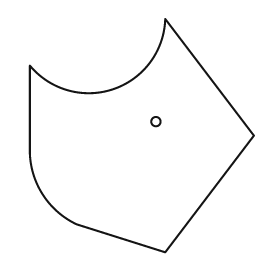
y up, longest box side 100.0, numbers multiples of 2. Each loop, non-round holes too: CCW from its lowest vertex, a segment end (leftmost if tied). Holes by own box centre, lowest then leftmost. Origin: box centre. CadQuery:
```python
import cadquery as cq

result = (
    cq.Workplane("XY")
    .moveTo(10.0, -50.0)
    .lineTo(48.0, 0.0)
    .lineTo(10.0, 50.0)
    .threePointArc((-12.0, 20.0), (-48.0, 30.0))
    .lineTo(-48.0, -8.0)
    .threePointArc((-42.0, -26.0), (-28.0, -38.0))
    .close()
    .moveTo(6.0, 6.0)
    .circle(2.0)
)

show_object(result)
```